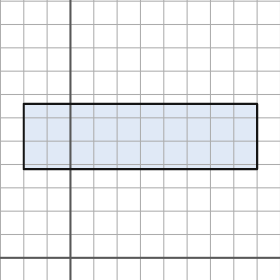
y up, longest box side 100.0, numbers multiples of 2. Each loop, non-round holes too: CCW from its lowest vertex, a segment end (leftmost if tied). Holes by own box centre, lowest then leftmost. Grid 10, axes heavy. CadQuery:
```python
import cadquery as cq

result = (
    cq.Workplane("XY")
    .moveTo(-20.0, 38.0)
    .lineTo(80.0, 38.0)
    .lineTo(80.0, 66.0)
    .lineTo(-20.0, 66.0)
    .close()
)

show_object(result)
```